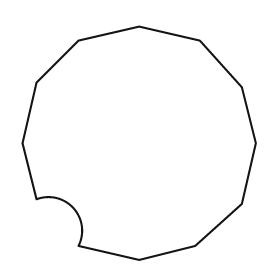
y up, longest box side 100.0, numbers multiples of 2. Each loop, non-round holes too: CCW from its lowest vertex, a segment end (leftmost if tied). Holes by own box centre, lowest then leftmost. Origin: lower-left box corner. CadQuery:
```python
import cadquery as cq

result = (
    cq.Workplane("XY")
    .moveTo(50.0, 0.0)
    .lineTo(74.0, 6.0)
    .lineTo(94.0, 24.0)
    .lineTo(100.0, 50.0)
    .lineTo(94.0, 74.0)
    .lineTo(76.0, 94.0)
    .lineTo(50.0, 100.0)
    .lineTo(24.0, 94.0)
    .lineTo(6.0, 76.0)
    .lineTo(0.0, 50.0)
    .lineTo(6.0, 26.0)
    .threePointArc((22.0, 22.0), (24.0, 6.0))
    .close()
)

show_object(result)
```